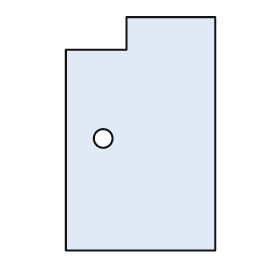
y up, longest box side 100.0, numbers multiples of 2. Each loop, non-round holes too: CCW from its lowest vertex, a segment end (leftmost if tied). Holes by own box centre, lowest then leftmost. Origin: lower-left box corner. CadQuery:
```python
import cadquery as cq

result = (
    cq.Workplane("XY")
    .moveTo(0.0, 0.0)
    .lineTo(64.0, 0.0)
    .lineTo(64.0, 100.0)
    .lineTo(26.0, 100.0)
    .lineTo(26.0, 86.0)
    .lineTo(0.0, 86.0)
    .close()
    .moveTo(16.0, 48.0)
    .circle(4.0)
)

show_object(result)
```